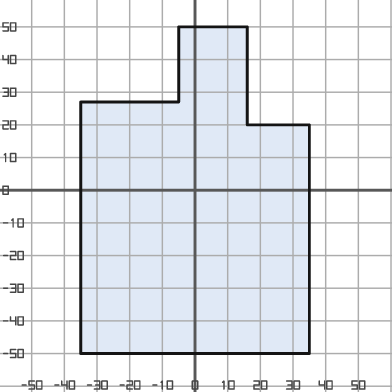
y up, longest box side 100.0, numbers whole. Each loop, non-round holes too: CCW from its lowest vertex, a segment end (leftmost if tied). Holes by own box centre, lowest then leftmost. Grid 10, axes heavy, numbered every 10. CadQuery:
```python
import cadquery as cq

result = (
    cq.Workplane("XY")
    .moveTo(-35.0, -50.0)
    .lineTo(35.0, -50.0)
    .lineTo(35.0, 20.0)
    .lineTo(16.0, 20.0)
    .lineTo(16.0, 50.0)
    .lineTo(-5.0, 50.0)
    .lineTo(-5.0, 27.0)
    .lineTo(-35.0, 27.0)
    .close()
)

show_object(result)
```